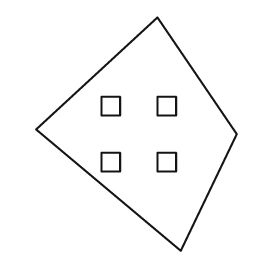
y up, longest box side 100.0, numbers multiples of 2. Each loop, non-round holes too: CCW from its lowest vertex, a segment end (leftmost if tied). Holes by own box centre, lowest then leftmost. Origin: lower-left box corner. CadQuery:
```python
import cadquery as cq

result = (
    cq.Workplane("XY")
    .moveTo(62.0, 0.0)
    .lineTo(86.0, 50.0)
    .lineTo(52.0, 100.0)
    .lineTo(0.0, 52.0)
    .close()
    .moveTo(28.0, 34.0)
    .lineTo(36.0, 34.0)
    .lineTo(36.0, 42.0)
    .lineTo(28.0, 42.0)
    .close()
    .moveTo(52.0, 34.0)
    .lineTo(60.0, 34.0)
    .lineTo(60.0, 42.0)
    .lineTo(52.0, 42.0)
    .close()
    .moveTo(28.0, 58.0)
    .lineTo(36.0, 58.0)
    .lineTo(36.0, 66.0)
    .lineTo(28.0, 66.0)
    .close()
    .moveTo(52.0, 58.0)
    .lineTo(60.0, 58.0)
    .lineTo(60.0, 66.0)
    .lineTo(52.0, 66.0)
    .close()
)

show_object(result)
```